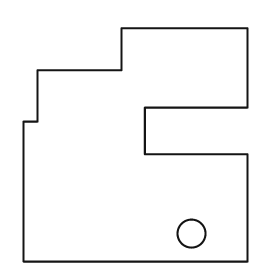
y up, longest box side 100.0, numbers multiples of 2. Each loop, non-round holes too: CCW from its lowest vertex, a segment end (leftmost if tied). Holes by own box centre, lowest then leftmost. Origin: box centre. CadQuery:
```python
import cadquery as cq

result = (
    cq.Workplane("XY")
    .moveTo(-48.0, -50.0)
    .lineTo(48.0, -50.0)
    .lineTo(48.0, -4.0)
    .lineTo(4.0, -4.0)
    .lineTo(4.0, 16.0)
    .lineTo(48.0, 16.0)
    .lineTo(48.0, 50.0)
    .lineTo(-6.0, 50.0)
    .lineTo(-6.0, 32.0)
    .lineTo(-42.0, 32.0)
    .lineTo(-42.0, 10.0)
    .lineTo(-48.0, 10.0)
    .close()
    .moveTo(24.0, -38.0)
    .circle(6.0)
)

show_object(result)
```